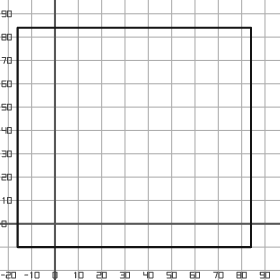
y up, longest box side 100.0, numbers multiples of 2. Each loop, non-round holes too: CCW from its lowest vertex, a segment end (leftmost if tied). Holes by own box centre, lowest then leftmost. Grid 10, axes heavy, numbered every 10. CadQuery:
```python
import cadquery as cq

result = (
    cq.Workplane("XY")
    .moveTo(-16.0, -10.0)
    .lineTo(84.0, -10.0)
    .lineTo(84.0, 84.0)
    .lineTo(-16.0, 84.0)
    .close()
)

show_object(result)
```